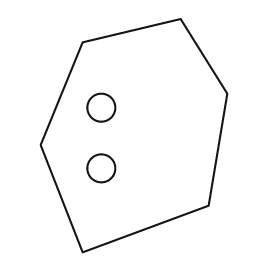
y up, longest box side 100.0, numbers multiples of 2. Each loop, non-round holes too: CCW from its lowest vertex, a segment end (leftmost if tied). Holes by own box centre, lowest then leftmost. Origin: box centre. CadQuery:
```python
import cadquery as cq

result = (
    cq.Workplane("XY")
    .moveTo(-22.0, -50.0)
    .lineTo(32.0, -30.0)
    .lineTo(40.0, 18.0)
    .lineTo(20.0, 50.0)
    .lineTo(-22.0, 40.0)
    .lineTo(-40.0, -4.0)
    .close()
    .moveTo(-14.0, -14.0)
    .circle(6.0)
    .moveTo(-14.0, 12.0)
    .circle(6.0)
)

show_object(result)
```